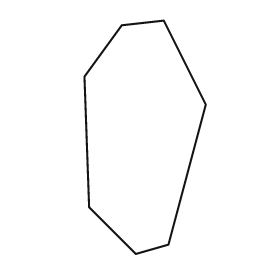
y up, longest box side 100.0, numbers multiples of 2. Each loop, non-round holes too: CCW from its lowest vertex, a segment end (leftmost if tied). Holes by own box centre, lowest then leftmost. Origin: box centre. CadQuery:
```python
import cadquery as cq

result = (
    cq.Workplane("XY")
    .moveTo(-4.0, -50.0)
    .lineTo(10.0, -46.0)
    .lineTo(26.0, 14.0)
    .lineTo(8.0, 50.0)
    .lineTo(-10.0, 48.0)
    .lineTo(-26.0, 26.0)
    .lineTo(-24.0, -30.0)
    .close()
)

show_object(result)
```